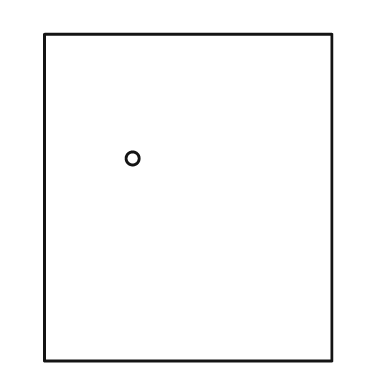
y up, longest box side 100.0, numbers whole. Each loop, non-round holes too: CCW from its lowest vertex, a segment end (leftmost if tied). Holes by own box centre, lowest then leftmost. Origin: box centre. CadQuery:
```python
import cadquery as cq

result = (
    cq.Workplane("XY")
    .moveTo(-44.0, -50.0)
    .lineTo(44.0, -50.0)
    .lineTo(44.0, 50.0)
    .lineTo(-44.0, 50.0)
    .close()
    .moveTo(-17.0, 12.0)
    .circle(2.0)
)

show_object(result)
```